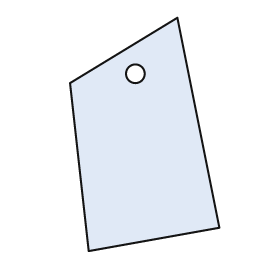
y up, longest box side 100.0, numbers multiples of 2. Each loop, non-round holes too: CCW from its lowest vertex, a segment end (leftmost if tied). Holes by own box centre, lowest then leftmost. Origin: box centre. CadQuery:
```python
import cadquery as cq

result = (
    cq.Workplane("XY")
    .moveTo(-24.0, -50.0)
    .lineTo(32.0, -40.0)
    .lineTo(14.0, 50.0)
    .lineTo(-32.0, 22.0)
    .close()
    .moveTo(-4.0, 26.0)
    .circle(4.0)
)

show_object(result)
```